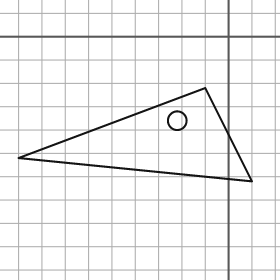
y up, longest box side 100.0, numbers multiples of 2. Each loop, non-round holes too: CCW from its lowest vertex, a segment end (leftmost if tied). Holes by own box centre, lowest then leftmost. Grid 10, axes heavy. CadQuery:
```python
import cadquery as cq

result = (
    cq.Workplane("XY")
    .moveTo(10.0, -62.0)
    .lineTo(-10.0, -22.0)
    .lineTo(-90.0, -52.0)
    .close()
    .moveTo(-22.0, -36.0)
    .circle(4.0)
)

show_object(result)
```